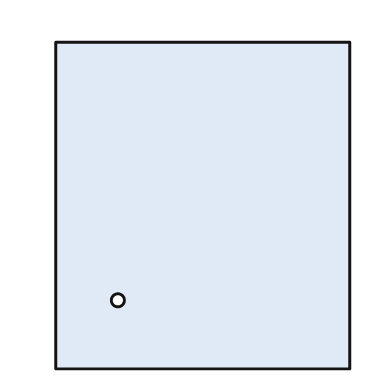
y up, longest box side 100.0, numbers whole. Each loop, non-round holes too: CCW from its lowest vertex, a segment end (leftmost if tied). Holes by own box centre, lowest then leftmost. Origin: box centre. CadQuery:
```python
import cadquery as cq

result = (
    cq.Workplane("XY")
    .moveTo(-45.0, -50.0)
    .lineTo(45.0, -50.0)
    .lineTo(45.0, 50.0)
    .lineTo(-45.0, 50.0)
    .close()
    .moveTo(-26.0, -29.0)
    .circle(2.0)
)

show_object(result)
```